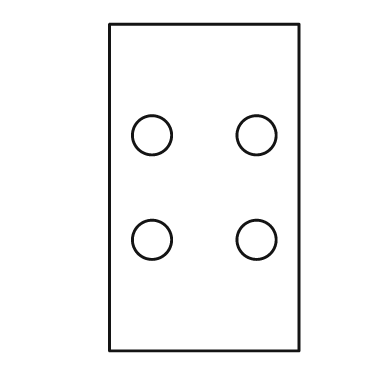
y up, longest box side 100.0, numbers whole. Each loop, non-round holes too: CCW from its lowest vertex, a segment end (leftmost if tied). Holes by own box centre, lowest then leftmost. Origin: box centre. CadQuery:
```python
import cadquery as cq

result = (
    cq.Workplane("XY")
    .moveTo(-29.0, -50.0)
    .lineTo(29.0, -50.0)
    .lineTo(29.0, 50.0)
    .lineTo(-29.0, 50.0)
    .close()
    .moveTo(-16.0, -16.0)
    .circle(6.0)
    .moveTo(16.0, -16.0)
    .circle(6.0)
    .moveTo(-16.0, 16.0)
    .circle(6.0)
    .moveTo(16.0, 16.0)
    .circle(6.0)
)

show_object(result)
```